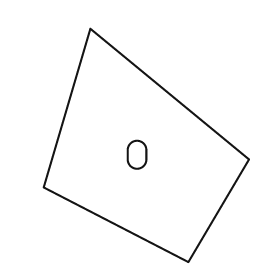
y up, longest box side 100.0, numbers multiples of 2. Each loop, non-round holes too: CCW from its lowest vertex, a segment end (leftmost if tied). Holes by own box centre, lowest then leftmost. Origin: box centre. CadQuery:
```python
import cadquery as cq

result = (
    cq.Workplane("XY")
    .moveTo(18.0, -50.0)
    .lineTo(44.0, -6.0)
    .lineTo(-24.0, 50.0)
    .lineTo(-44.0, -18.0)
    .close()
    .moveTo(-8.0, -6.0)
    .threePointArc((-4.0, -10.0), (0.0, -6.0))
    .lineTo(0.0, -2.0)
    .threePointArc((-4.0, 2.0), (-8.0, -2.0))
    .close()
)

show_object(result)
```